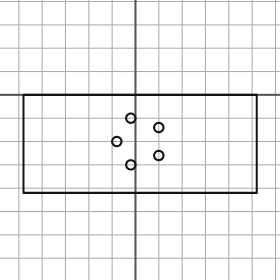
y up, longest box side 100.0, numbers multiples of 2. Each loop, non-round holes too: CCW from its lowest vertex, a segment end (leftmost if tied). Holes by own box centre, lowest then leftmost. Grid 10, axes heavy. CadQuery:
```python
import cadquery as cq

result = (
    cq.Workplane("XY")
    .moveTo(-48.0, -42.0)
    .lineTo(52.0, -42.0)
    .lineTo(52.0, 0.0)
    .lineTo(-48.0, 0.0)
    .close()
    .moveTo(-2.0, -30.0)
    .circle(2.0)
    .moveTo(10.0, -26.0)
    .circle(2.0)
    .moveTo(-8.0, -20.0)
    .circle(2.0)
    .moveTo(10.0, -14.0)
    .circle(2.0)
    .moveTo(-2.0, -10.0)
    .circle(2.0)
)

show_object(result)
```